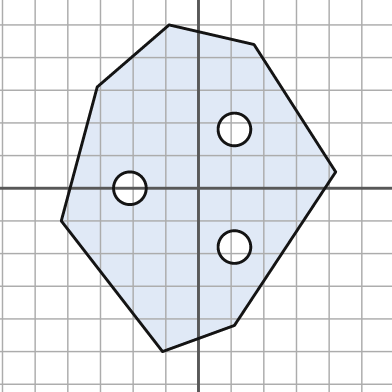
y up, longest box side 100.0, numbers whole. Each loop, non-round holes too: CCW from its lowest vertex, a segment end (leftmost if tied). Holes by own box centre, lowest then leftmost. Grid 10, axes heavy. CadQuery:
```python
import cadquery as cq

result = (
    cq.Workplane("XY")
    .moveTo(-11.0, -50.0)
    .lineTo(11.0, -42.0)
    .lineTo(42.0, 5.0)
    .lineTo(17.0, 44.0)
    .lineTo(-9.0, 50.0)
    .lineTo(-31.0, 31.0)
    .lineTo(-42.0, -10.0)
    .close()
    .moveTo(11.0, -18.0)
    .circle(5.0)
    .moveTo(-21.0, 0.0)
    .circle(5.0)
    .moveTo(11.0, 18.0)
    .circle(5.0)
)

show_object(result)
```